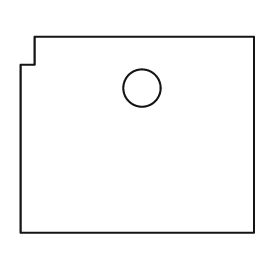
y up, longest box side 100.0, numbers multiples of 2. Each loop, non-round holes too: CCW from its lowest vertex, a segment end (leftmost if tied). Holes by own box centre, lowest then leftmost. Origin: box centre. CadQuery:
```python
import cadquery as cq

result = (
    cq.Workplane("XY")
    .moveTo(-50.0, -42.0)
    .lineTo(50.0, -42.0)
    .lineTo(50.0, 42.0)
    .lineTo(-44.0, 42.0)
    .lineTo(-44.0, 30.0)
    .lineTo(-50.0, 30.0)
    .close()
    .moveTo(2.0, 20.0)
    .circle(8.0)
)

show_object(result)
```